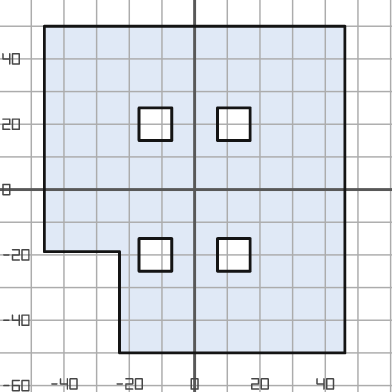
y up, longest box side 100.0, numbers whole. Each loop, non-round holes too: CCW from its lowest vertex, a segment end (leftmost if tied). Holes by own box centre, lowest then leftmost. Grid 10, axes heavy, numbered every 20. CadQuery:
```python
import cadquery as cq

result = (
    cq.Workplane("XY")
    .moveTo(-23.0, -50.0)
    .lineTo(46.0, -50.0)
    .lineTo(46.0, 50.0)
    .lineTo(-46.0, 50.0)
    .lineTo(-46.0, -19.0)
    .lineTo(-23.0, -19.0)
    .close()
    .moveTo(-17.0, -25.0)
    .lineTo(-7.0, -25.0)
    .lineTo(-7.0, -15.0)
    .lineTo(-17.0, -15.0)
    .close()
    .moveTo(7.0, -25.0)
    .lineTo(17.0, -25.0)
    .lineTo(17.0, -15.0)
    .lineTo(7.0, -15.0)
    .close()
    .moveTo(-17.0, 15.0)
    .lineTo(-7.0, 15.0)
    .lineTo(-7.0, 25.0)
    .lineTo(-17.0, 25.0)
    .close()
    .moveTo(7.0, 15.0)
    .lineTo(17.0, 15.0)
    .lineTo(17.0, 25.0)
    .lineTo(7.0, 25.0)
    .close()
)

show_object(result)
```